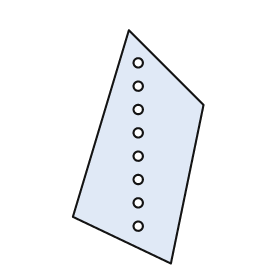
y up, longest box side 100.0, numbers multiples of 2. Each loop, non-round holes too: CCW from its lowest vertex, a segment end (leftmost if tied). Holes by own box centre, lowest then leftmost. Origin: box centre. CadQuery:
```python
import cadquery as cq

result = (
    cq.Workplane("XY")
    .moveTo(14.0, -50.0)
    .lineTo(28.0, 18.0)
    .lineTo(-4.0, 50.0)
    .lineTo(-28.0, -30.0)
    .close()
    .moveTo(0.0, -34.0)
    .circle(2.0)
    .moveTo(0.0, -24.0)
    .circle(2.0)
    .moveTo(0.0, -14.0)
    .circle(2.0)
    .moveTo(0.0, -4.0)
    .circle(2.0)
    .moveTo(0.0, 6.0)
    .circle(2.0)
    .moveTo(0.0, 16.0)
    .circle(2.0)
    .moveTo(0.0, 26.0)
    .circle(2.0)
    .moveTo(0.0, 36.0)
    .circle(2.0)
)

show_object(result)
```